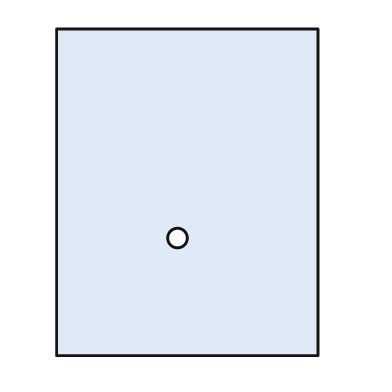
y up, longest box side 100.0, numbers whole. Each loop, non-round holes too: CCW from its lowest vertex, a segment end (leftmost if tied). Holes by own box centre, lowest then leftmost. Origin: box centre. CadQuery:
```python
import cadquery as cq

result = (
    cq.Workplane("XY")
    .moveTo(-40.0, -50.0)
    .lineTo(40.0, -50.0)
    .lineTo(40.0, 50.0)
    .lineTo(-40.0, 50.0)
    .close()
    .moveTo(-3.0, -14.0)
    .circle(3.0)
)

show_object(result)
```